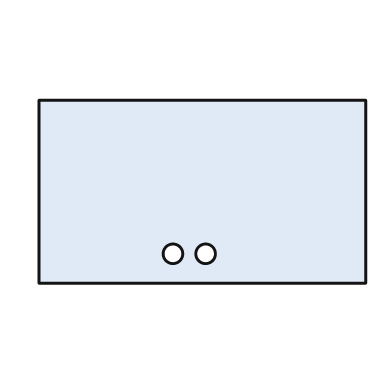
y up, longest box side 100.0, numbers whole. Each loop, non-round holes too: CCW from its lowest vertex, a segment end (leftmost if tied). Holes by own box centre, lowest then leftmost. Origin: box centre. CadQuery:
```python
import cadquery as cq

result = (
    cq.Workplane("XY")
    .moveTo(-50.0, -28.0)
    .lineTo(50.0, -28.0)
    .lineTo(50.0, 28.0)
    .lineTo(-50.0, 28.0)
    .close()
    .moveTo(-9.0, -19.0)
    .circle(3.0)
    .moveTo(1.0, -19.0)
    .circle(3.0)
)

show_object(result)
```